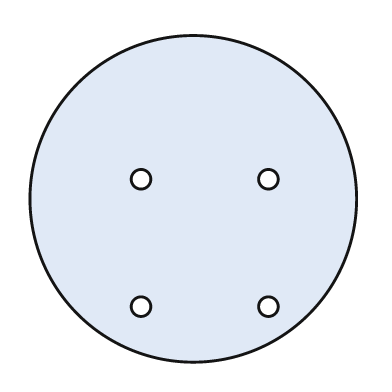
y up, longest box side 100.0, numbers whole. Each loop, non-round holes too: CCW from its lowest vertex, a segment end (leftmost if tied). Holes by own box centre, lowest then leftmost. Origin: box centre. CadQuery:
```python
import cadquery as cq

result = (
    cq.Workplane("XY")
    .moveTo(0.0, 0.0)
    .circle(50.0)
    .moveTo(-16.0, -33.0)
    .circle(3.0)
    .moveTo(23.0, -33.0)
    .circle(3.0)
    .moveTo(-16.0, 6.0)
    .circle(3.0)
    .moveTo(23.0, 6.0)
    .circle(3.0)
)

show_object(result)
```